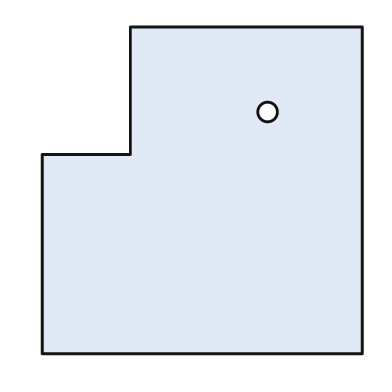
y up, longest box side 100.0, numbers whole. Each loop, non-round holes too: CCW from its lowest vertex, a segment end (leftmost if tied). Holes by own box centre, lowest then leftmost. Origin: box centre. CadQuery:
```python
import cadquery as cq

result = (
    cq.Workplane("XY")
    .moveTo(-49.0, -50.0)
    .lineTo(49.0, -50.0)
    .lineTo(49.0, 50.0)
    .lineTo(-22.0, 50.0)
    .lineTo(-22.0, 11.0)
    .lineTo(-49.0, 11.0)
    .close()
    .moveTo(20.0, 24.0)
    .circle(3.0)
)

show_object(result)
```